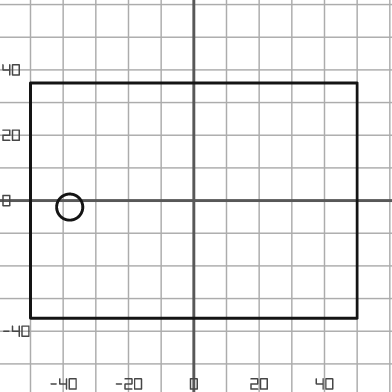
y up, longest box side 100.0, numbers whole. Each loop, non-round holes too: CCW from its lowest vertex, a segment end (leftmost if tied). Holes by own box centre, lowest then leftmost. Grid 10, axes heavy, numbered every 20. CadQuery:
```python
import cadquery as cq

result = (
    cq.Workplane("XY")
    .moveTo(-50.0, -36.0)
    .lineTo(50.0, -36.0)
    .lineTo(50.0, 36.0)
    .lineTo(-50.0, 36.0)
    .close()
    .moveTo(-38.0, -2.0)
    .circle(4.0)
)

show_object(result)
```